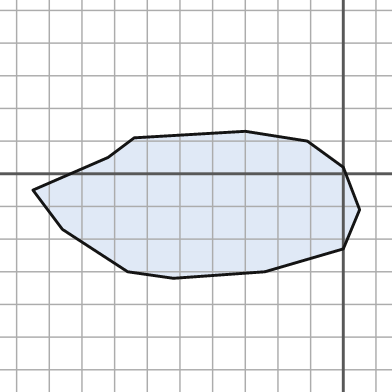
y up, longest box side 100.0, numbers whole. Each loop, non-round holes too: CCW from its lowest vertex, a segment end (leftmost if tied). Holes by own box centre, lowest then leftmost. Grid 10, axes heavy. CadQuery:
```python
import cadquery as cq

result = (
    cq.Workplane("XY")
    .moveTo(-52.0, -32.0)
    .lineTo(-24.0, -30.0)
    .lineTo(0.0, -23.0)
    .lineTo(5.0, -11.0)
    .lineTo(0.0, 2.0)
    .lineTo(-11.0, 10.0)
    .lineTo(-30.0, 13.0)
    .lineTo(-64.0, 11.0)
    .lineTo(-72.0, 5.0)
    .lineTo(-95.0, -5.0)
    .lineTo(-86.0, -17.0)
    .lineTo(-66.0, -30.0)
    .close()
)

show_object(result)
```